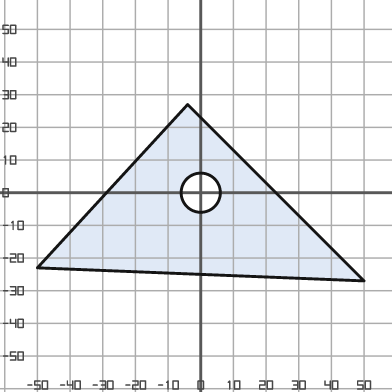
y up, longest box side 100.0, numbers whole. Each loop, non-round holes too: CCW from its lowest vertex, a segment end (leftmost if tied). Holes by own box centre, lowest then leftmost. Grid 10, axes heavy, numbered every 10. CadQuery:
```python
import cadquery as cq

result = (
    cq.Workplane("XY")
    .moveTo(50.0, -27.0)
    .lineTo(-4.0, 27.0)
    .lineTo(-50.0, -23.0)
    .close()
    .moveTo(0.0, 0.0)
    .circle(6.0)
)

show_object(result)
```